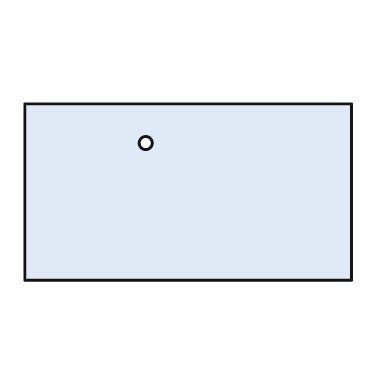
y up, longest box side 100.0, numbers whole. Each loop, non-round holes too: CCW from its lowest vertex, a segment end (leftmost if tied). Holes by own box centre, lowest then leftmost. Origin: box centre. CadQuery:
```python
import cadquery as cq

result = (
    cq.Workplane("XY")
    .moveTo(-50.0, -27.0)
    .lineTo(50.0, -27.0)
    .lineTo(50.0, 27.0)
    .lineTo(-50.0, 27.0)
    .close()
    .moveTo(-13.0, 15.0)
    .circle(2.0)
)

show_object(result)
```